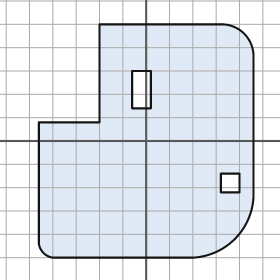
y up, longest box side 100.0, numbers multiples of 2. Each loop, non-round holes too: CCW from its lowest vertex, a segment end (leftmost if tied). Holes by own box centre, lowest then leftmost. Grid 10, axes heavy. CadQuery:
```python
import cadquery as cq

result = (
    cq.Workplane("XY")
    .moveTo(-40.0, -50.0)
    .lineTo(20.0, -50.0)
    .threePointArc((38.0, -42.0), (46.0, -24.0))
    .lineTo(46.0, 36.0)
    .threePointArc((42.0, 46.0), (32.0, 50.0))
    .lineTo(-20.0, 50.0)
    .lineTo(-20.0, 8.0)
    .lineTo(-46.0, 8.0)
    .lineTo(-46.0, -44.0)
    .threePointArc((-44.0, -48.0), (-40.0, -50.0))
    .close()
    .moveTo(32.0, -22.0)
    .lineTo(40.0, -22.0)
    .lineTo(40.0, -14.0)
    .lineTo(32.0, -14.0)
    .close()
    .moveTo(-6.0, 14.0)
    .lineTo(2.0, 14.0)
    .lineTo(2.0, 30.0)
    .lineTo(-6.0, 30.0)
    .close()
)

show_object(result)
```